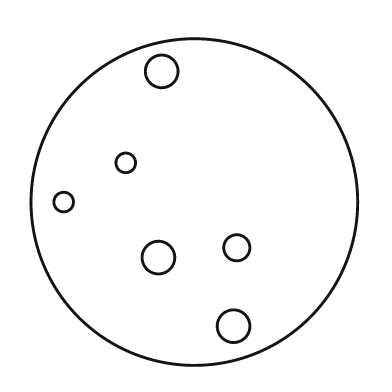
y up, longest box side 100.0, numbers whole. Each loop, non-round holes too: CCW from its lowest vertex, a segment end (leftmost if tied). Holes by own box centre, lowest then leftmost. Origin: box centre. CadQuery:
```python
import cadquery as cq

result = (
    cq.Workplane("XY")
    .moveTo(0.0, 0.0)
    .circle(50.0)
    .moveTo(12.0, -38.0)
    .circle(5.0)
    .moveTo(-11.0, -17.0)
    .circle(5.0)
    .moveTo(13.0, -14.0)
    .circle(4.0)
    .moveTo(-40.0, 0.0)
    .circle(3.0)
    .moveTo(-21.0, 12.0)
    .circle(3.0)
    .moveTo(-10.0, 40.0)
    .circle(5.0)
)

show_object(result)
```